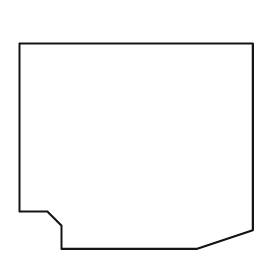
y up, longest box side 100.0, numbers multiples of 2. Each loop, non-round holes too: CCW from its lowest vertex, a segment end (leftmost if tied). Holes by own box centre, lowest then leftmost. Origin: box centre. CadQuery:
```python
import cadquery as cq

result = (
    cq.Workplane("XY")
    .moveTo(-32.0, -44.0)
    .lineTo(26.0, -44.0)
    .lineTo(50.0, -36.0)
    .lineTo(50.0, 44.0)
    .lineTo(-50.0, 44.0)
    .lineTo(-50.0, -28.0)
    .lineTo(-38.0, -28.0)
    .lineTo(-32.0, -34.0)
    .close()
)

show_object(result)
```